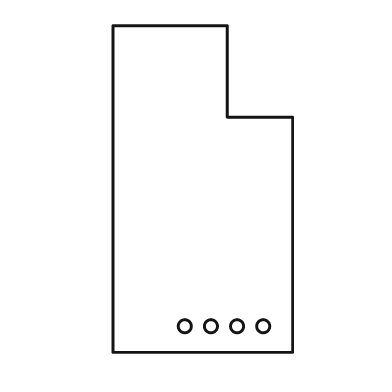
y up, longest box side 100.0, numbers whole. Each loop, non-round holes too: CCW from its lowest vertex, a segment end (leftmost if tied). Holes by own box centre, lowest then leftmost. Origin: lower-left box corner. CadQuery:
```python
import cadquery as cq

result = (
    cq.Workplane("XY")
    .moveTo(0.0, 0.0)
    .lineTo(55.0, 0.0)
    .lineTo(55.0, 72.0)
    .lineTo(35.0, 72.0)
    .lineTo(35.0, 100.0)
    .lineTo(0.0, 100.0)
    .close()
    .moveTo(22.0, 8.0)
    .circle(2.0)
    .moveTo(30.0, 8.0)
    .circle(2.0)
    .moveTo(38.0, 8.0)
    .circle(2.0)
    .moveTo(46.0, 8.0)
    .circle(2.0)
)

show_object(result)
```